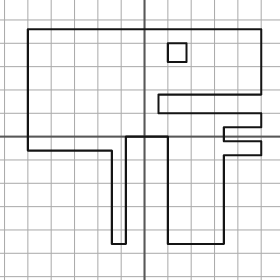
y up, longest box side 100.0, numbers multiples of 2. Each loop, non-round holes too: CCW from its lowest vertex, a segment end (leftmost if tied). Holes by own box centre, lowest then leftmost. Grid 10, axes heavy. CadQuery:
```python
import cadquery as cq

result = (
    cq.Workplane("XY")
    .moveTo(-14.0, -46.0)
    .lineTo(-8.0, -46.0)
    .lineTo(-8.0, 0.0)
    .lineTo(10.0, 0.0)
    .lineTo(10.0, -46.0)
    .lineTo(34.0, -46.0)
    .lineTo(34.0, -8.0)
    .lineTo(50.0, -8.0)
    .lineTo(50.0, -2.0)
    .lineTo(34.0, -2.0)
    .lineTo(34.0, 4.0)
    .lineTo(50.0, 4.0)
    .lineTo(50.0, 10.0)
    .lineTo(6.0, 10.0)
    .lineTo(6.0, 18.0)
    .lineTo(50.0, 18.0)
    .lineTo(50.0, 46.0)
    .lineTo(-50.0, 46.0)
    .lineTo(-50.0, -6.0)
    .lineTo(-14.0, -6.0)
    .close()
    .moveTo(10.0, 32.0)
    .lineTo(18.0, 32.0)
    .lineTo(18.0, 40.0)
    .lineTo(10.0, 40.0)
    .close()
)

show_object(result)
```